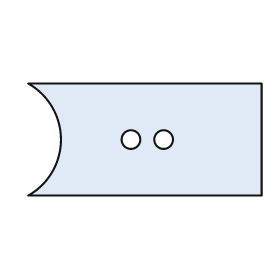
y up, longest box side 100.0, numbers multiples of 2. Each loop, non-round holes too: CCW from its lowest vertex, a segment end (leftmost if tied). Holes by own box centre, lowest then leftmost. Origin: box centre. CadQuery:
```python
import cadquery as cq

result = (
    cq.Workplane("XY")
    .moveTo(-50.0, -24.0)
    .lineTo(50.0, -24.0)
    .lineTo(50.0, 24.0)
    .lineTo(-50.0, 24.0)
    .threePointArc((-36.0, 0.0), (-50.0, -24.0))
    .close()
    .moveTo(-6.0, 0.0)
    .circle(4.0)
    .moveTo(8.0, 0.0)
    .circle(4.0)
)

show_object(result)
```